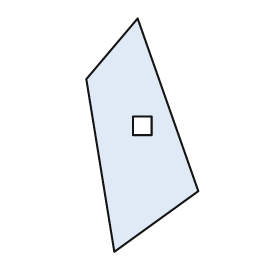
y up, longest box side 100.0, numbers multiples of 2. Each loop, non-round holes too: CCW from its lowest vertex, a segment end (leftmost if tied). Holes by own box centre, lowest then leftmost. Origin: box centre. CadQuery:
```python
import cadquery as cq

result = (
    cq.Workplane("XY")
    .moveTo(-12.0, -50.0)
    .lineTo(24.0, -24.0)
    .lineTo(-2.0, 50.0)
    .lineTo(-24.0, 24.0)
    .close()
    .moveTo(-4.0, 0.0)
    .lineTo(4.0, 0.0)
    .lineTo(4.0, 8.0)
    .lineTo(-4.0, 8.0)
    .close()
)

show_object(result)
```